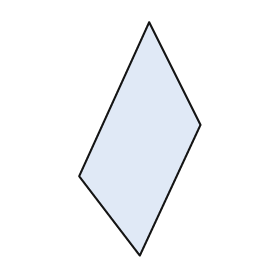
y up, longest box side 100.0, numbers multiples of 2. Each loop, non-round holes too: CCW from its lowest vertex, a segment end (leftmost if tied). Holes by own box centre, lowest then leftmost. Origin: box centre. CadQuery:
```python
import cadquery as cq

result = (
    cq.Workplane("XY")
    .moveTo(0.0, -50.0)
    .lineTo(26.0, 6.0)
    .lineTo(4.0, 50.0)
    .lineTo(-26.0, -16.0)
    .close()
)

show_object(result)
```